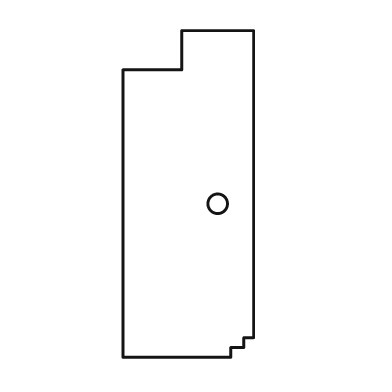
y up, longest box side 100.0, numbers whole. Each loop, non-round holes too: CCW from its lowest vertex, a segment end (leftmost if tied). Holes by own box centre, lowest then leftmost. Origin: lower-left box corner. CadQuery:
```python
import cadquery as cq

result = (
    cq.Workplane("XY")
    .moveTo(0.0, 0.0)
    .lineTo(33.0, 0.0)
    .lineTo(33.0, 3.0)
    .lineTo(37.0, 3.0)
    .lineTo(37.0, 6.0)
    .lineTo(40.0, 6.0)
    .lineTo(40.0, 100.0)
    .lineTo(18.0, 100.0)
    .lineTo(18.0, 88.0)
    .lineTo(0.0, 88.0)
    .close()
    .moveTo(29.0, 47.0)
    .circle(3.0)
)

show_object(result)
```